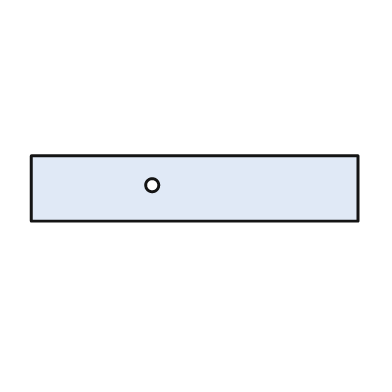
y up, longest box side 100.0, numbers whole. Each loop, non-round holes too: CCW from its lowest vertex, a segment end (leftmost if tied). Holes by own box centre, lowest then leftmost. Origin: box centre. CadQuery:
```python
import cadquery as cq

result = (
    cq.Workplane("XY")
    .moveTo(-50.0, -10.0)
    .lineTo(50.0, -10.0)
    .lineTo(50.0, 10.0)
    .lineTo(-50.0, 10.0)
    .close()
    .moveTo(-13.0, 1.0)
    .circle(2.0)
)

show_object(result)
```